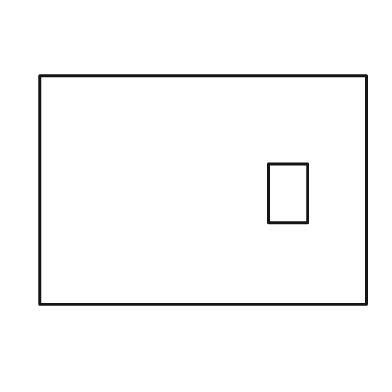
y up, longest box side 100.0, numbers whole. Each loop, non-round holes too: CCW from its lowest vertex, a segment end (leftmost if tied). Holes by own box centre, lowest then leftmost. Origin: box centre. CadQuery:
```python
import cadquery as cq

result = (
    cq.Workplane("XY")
    .moveTo(-50.0, -35.0)
    .lineTo(50.0, -35.0)
    .lineTo(50.0, 35.0)
    .lineTo(-50.0, 35.0)
    .close()
    .moveTo(20.0, -10.0)
    .lineTo(32.0, -10.0)
    .lineTo(32.0, 8.0)
    .lineTo(20.0, 8.0)
    .close()
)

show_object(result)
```